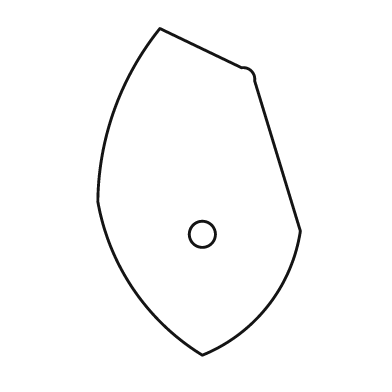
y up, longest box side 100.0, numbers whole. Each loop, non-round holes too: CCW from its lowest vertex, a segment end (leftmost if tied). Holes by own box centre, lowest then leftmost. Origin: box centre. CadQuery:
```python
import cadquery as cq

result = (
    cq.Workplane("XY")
    .moveTo(1.0, -50.0)
    .threePointArc((21.0, -35.0), (31.0, -12.0))
    .lineTo(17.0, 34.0)
    .threePointArc((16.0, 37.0), (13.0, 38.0))
    .lineTo(-12.0, 50.0)
    .threePointArc((-26.0, 25.0), (-31.0, -3.0))
    .threePointArc((-20.0, -30.0), (1.0, -50.0))
    .close()
    .moveTo(1.0, -13.0)
    .circle(4.0)
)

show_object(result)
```